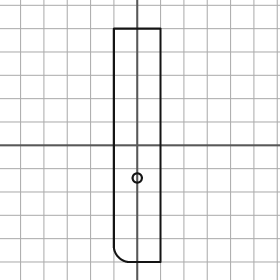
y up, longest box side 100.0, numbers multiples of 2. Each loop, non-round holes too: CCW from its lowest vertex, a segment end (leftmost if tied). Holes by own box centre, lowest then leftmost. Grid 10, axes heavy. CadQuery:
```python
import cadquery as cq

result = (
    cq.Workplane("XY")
    .moveTo(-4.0, -50.0)
    .lineTo(10.0, -50.0)
    .lineTo(10.0, 50.0)
    .lineTo(-10.0, 50.0)
    .lineTo(-10.0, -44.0)
    .threePointArc((-8.0, -48.0), (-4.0, -50.0))
    .close()
    .moveTo(0.0, -14.0)
    .circle(2.0)
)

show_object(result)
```